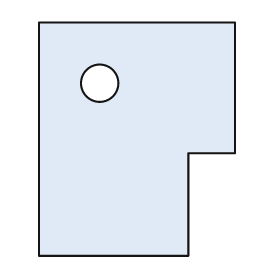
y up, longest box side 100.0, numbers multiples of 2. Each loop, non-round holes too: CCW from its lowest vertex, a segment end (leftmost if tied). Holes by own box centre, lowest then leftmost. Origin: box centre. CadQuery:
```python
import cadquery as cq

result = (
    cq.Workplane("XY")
    .moveTo(-42.0, -50.0)
    .lineTo(22.0, -50.0)
    .lineTo(22.0, -6.0)
    .lineTo(42.0, -6.0)
    .lineTo(42.0, 50.0)
    .lineTo(-42.0, 50.0)
    .close()
    .moveTo(-16.0, 24.0)
    .circle(8.0)
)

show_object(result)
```